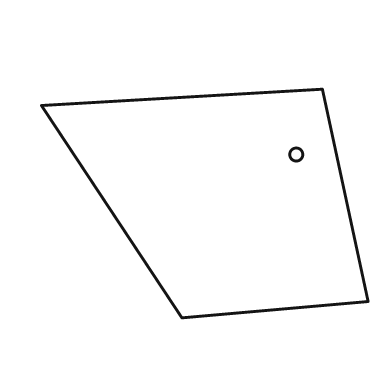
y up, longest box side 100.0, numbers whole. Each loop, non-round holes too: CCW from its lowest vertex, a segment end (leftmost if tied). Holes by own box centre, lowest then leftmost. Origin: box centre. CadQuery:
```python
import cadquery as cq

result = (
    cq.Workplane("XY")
    .moveTo(-7.0, -35.0)
    .lineTo(50.0, -30.0)
    .lineTo(36.0, 35.0)
    .lineTo(-50.0, 30.0)
    .close()
    .moveTo(28.0, 15.0)
    .circle(2.0)
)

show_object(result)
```